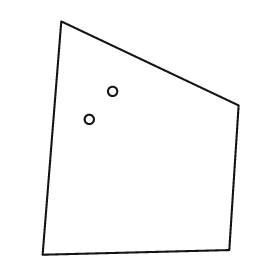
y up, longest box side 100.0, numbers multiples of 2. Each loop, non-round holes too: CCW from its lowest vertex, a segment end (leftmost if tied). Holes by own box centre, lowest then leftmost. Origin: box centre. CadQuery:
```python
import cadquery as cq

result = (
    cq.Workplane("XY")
    .moveTo(-42.0, -50.0)
    .lineTo(38.0, -48.0)
    .lineTo(42.0, 14.0)
    .lineTo(-34.0, 50.0)
    .close()
    .moveTo(-22.0, 8.0)
    .circle(2.0)
    .moveTo(-12.0, 20.0)
    .circle(2.0)
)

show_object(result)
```